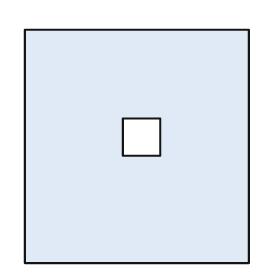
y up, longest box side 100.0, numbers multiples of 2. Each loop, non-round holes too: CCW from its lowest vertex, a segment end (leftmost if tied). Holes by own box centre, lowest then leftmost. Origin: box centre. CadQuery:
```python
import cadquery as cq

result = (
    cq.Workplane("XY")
    .moveTo(-48.0, -50.0)
    .lineTo(48.0, -50.0)
    .lineTo(48.0, 50.0)
    .lineTo(-48.0, 50.0)
    .close()
    .moveTo(-6.0, -4.0)
    .lineTo(10.0, -4.0)
    .lineTo(10.0, 12.0)
    .lineTo(-6.0, 12.0)
    .close()
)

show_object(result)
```